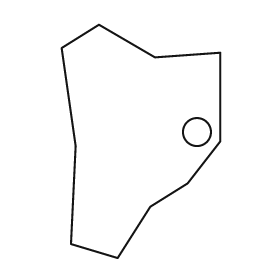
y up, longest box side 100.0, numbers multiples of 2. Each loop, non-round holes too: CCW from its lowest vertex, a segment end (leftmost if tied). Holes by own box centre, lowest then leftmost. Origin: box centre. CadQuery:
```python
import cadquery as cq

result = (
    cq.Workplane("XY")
    .moveTo(-10.0, -50.0)
    .lineTo(4.0, -28.0)
    .lineTo(20.0, -18.0)
    .lineTo(34.0, 0.0)
    .lineTo(34.0, 38.0)
    .lineTo(6.0, 36.0)
    .lineTo(-18.0, 50.0)
    .lineTo(-34.0, 40.0)
    .lineTo(-28.0, -2.0)
    .lineTo(-30.0, -44.0)
    .close()
    .moveTo(24.0, 4.0)
    .circle(6.0)
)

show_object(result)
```